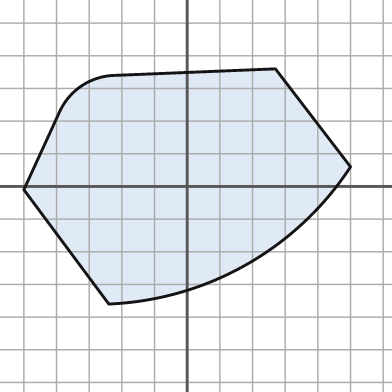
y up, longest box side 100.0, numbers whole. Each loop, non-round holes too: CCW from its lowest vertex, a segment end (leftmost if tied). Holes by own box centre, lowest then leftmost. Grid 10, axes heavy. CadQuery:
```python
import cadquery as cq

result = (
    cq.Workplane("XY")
    .moveTo(-24.0, -36.0)
    .threePointArc((18.0, -24.0), (50.0, 6.0))
    .lineTo(27.0, 36.0)
    .lineTo(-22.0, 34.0)
    .threePointArc((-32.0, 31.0), (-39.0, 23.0))
    .lineTo(-50.0, -1.0)
    .close()
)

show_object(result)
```